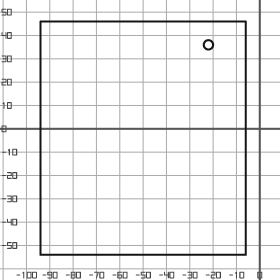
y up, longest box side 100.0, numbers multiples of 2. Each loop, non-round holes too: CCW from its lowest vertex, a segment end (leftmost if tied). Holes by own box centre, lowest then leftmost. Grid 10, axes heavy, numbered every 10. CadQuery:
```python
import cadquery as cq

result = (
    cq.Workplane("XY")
    .moveTo(-94.0, -54.0)
    .lineTo(-6.0, -54.0)
    .lineTo(-6.0, 46.0)
    .lineTo(-94.0, 46.0)
    .close()
    .moveTo(-22.0, 36.0)
    .circle(2.0)
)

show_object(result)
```